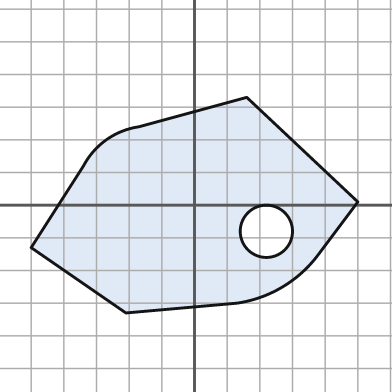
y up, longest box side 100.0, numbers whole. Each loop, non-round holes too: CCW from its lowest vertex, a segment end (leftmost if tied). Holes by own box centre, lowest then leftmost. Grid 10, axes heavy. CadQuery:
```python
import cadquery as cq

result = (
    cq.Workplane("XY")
    .moveTo(-21.0, -33.0)
    .lineTo(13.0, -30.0)
    .threePointArc((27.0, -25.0), (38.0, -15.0))
    .lineTo(50.0, 1.0)
    .lineTo(16.0, 33.0)
    .lineTo(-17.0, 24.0)
    .threePointArc((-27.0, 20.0), (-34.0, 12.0))
    .lineTo(-50.0, -13.0)
    .close()
    .moveTo(22.0, -8.0)
    .circle(8.0)
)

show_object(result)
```